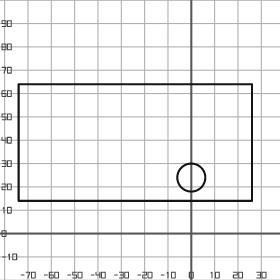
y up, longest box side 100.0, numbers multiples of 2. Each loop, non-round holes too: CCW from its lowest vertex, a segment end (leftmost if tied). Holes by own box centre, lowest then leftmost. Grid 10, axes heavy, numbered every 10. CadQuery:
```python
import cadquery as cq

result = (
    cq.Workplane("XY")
    .moveTo(-74.0, 14.0)
    .lineTo(26.0, 14.0)
    .lineTo(26.0, 64.0)
    .lineTo(-74.0, 64.0)
    .close()
    .moveTo(0.0, 24.0)
    .circle(6.0)
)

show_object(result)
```